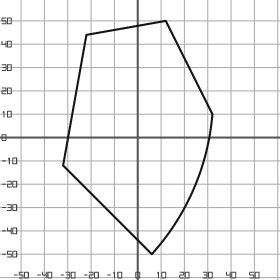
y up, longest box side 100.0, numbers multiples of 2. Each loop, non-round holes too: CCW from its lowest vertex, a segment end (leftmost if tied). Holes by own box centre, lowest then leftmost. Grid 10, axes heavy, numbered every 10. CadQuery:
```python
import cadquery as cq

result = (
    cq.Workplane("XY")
    .moveTo(6.0, -50.0)
    .threePointArc((24.0, -22.0), (32.0, 10.0))
    .lineTo(12.0, 50.0)
    .lineTo(-22.0, 44.0)
    .lineTo(-32.0, -12.0)
    .close()
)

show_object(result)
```